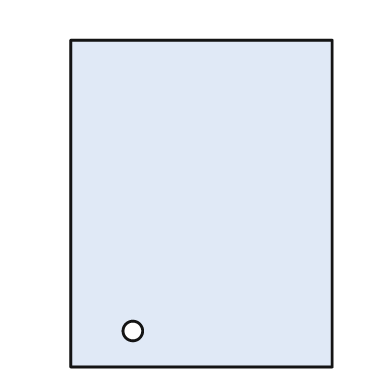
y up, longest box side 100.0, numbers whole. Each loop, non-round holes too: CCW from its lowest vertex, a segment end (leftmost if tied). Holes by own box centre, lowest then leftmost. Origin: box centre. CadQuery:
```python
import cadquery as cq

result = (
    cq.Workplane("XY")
    .moveTo(-40.0, -50.0)
    .lineTo(40.0, -50.0)
    .lineTo(40.0, 50.0)
    .lineTo(-40.0, 50.0)
    .close()
    .moveTo(-21.0, -39.0)
    .circle(3.0)
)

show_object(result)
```